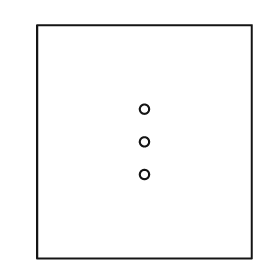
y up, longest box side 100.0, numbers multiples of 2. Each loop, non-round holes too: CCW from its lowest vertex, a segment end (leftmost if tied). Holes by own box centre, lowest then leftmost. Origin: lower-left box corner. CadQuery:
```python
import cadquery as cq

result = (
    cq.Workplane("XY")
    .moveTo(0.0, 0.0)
    .lineTo(92.0, 0.0)
    .lineTo(92.0, 100.0)
    .lineTo(0.0, 100.0)
    .close()
    .moveTo(46.0, 36.0)
    .circle(2.0)
    .moveTo(46.0, 50.0)
    .circle(2.0)
    .moveTo(46.0, 64.0)
    .circle(2.0)
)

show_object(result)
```